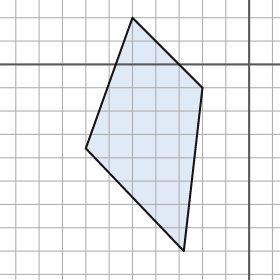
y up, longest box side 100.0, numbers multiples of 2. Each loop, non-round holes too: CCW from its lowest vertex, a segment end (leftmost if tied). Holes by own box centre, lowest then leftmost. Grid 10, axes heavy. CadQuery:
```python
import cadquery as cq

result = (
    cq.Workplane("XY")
    .moveTo(-28.0, -80.0)
    .lineTo(-20.0, -10.0)
    .lineTo(-50.0, 20.0)
    .lineTo(-70.0, -36.0)
    .close()
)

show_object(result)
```